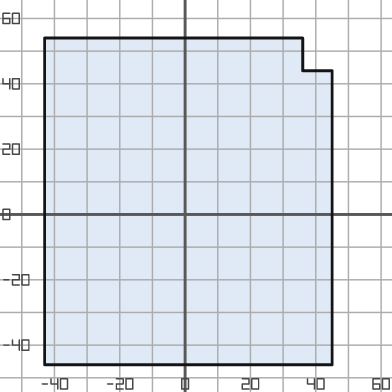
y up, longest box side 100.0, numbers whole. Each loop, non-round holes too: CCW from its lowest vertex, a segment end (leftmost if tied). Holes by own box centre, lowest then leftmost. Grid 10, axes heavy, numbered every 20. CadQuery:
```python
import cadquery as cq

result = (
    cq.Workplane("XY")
    .moveTo(-43.0, -46.0)
    .lineTo(45.0, -46.0)
    .lineTo(45.0, 44.0)
    .lineTo(36.0, 44.0)
    .lineTo(36.0, 54.0)
    .lineTo(-43.0, 54.0)
    .close()
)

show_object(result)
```